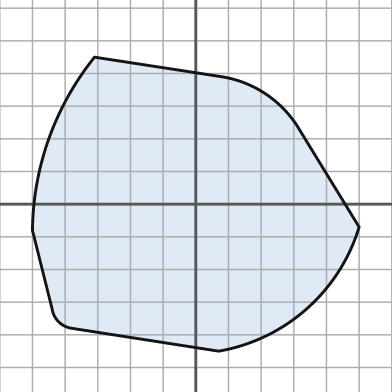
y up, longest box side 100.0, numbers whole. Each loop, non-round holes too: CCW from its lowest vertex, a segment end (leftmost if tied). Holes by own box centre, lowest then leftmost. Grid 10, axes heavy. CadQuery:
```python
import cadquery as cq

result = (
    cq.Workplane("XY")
    .moveTo(7.0, -45.0)
    .threePointArc((34.0, -32.0), (50.0, -7.0))
    .lineTo(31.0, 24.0)
    .threePointArc((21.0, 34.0), (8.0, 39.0))
    .lineTo(-31.0, 45.0)
    .threePointArc((-45.0, 20.0), (-50.0, -8.0))
    .lineTo(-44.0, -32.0)
    .threePointArc((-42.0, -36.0), (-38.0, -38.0))
    .close()
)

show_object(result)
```